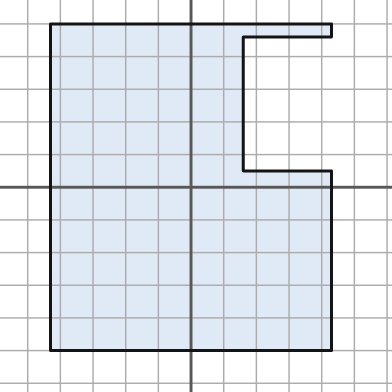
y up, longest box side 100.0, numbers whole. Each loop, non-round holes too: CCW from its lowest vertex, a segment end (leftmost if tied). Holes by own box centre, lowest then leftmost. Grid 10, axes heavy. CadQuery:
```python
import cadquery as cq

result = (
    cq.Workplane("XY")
    .moveTo(-43.0, -50.0)
    .lineTo(43.0, -50.0)
    .lineTo(43.0, 5.0)
    .lineTo(16.0, 5.0)
    .lineTo(16.0, 46.0)
    .lineTo(43.0, 46.0)
    .lineTo(43.0, 50.0)
    .lineTo(-43.0, 50.0)
    .close()
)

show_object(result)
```